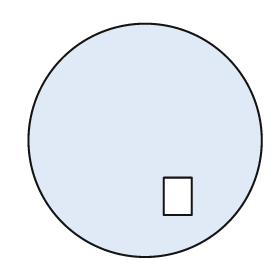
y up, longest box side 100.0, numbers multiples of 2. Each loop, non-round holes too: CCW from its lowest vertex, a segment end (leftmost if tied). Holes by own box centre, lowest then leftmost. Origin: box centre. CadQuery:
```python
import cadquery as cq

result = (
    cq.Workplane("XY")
    .moveTo(0.0, 0.0)
    .circle(50.0)
    .moveTo(8.0, -32.0)
    .lineTo(20.0, -32.0)
    .lineTo(20.0, -16.0)
    .lineTo(8.0, -16.0)
    .close()
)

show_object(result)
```